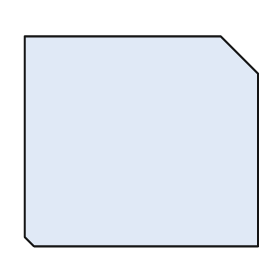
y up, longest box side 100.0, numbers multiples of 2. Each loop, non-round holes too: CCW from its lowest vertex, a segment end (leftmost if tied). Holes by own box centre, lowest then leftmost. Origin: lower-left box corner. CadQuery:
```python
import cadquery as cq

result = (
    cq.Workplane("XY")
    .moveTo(4.0, 0.0)
    .lineTo(100.0, 0.0)
    .lineTo(100.0, 74.0)
    .lineTo(84.0, 90.0)
    .lineTo(0.0, 90.0)
    .lineTo(0.0, 4.0)
    .close()
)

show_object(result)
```